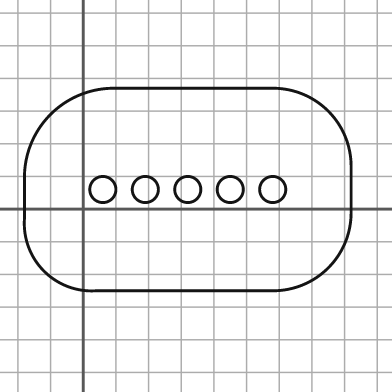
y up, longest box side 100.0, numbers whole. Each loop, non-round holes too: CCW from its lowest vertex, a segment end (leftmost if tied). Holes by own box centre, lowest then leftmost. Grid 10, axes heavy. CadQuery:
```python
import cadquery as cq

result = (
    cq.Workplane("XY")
    .moveTo(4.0, -25.0)
    .lineTo(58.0, -25.0)
    .threePointArc((75.0, -18.0), (82.0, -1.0))
    .lineTo(82.0, 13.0)
    .threePointArc((75.0, 30.0), (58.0, 37.0))
    .lineTo(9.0, 37.0)
    .threePointArc((-10.0, 29.0), (-18.0, 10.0))
    .lineTo(-18.0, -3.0)
    .threePointArc((-12.0, -19.0), (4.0, -25.0))
    .close()
    .moveTo(6.0, 6.0)
    .circle(4.0)
    .moveTo(19.0, 6.0)
    .circle(4.0)
    .moveTo(32.0, 6.0)
    .circle(4.0)
    .moveTo(45.0, 6.0)
    .circle(4.0)
    .moveTo(58.0, 6.0)
    .circle(4.0)
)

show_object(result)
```